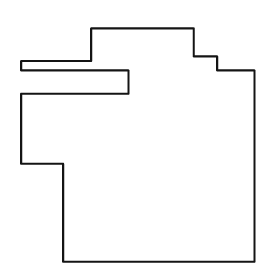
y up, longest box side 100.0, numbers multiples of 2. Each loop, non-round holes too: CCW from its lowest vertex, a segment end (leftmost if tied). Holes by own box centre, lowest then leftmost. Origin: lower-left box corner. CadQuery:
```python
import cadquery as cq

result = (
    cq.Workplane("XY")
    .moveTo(18.0, 0.0)
    .lineTo(100.0, 0.0)
    .lineTo(100.0, 82.0)
    .lineTo(84.0, 82.0)
    .lineTo(84.0, 88.0)
    .lineTo(74.0, 88.0)
    .lineTo(74.0, 100.0)
    .lineTo(30.0, 100.0)
    .lineTo(30.0, 86.0)
    .lineTo(0.0, 86.0)
    .lineTo(0.0, 82.0)
    .lineTo(46.0, 82.0)
    .lineTo(46.0, 72.0)
    .lineTo(0.0, 72.0)
    .lineTo(0.0, 42.0)
    .lineTo(18.0, 42.0)
    .close()
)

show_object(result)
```